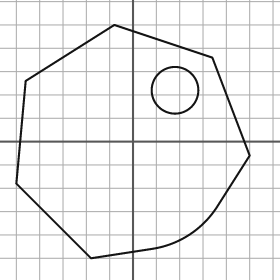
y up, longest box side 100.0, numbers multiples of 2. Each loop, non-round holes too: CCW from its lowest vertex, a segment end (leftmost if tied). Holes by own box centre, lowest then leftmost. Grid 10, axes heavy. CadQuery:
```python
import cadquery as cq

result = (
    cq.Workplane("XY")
    .moveTo(-18.0, -50.0)
    .lineTo(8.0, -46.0)
    .threePointArc((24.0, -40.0), (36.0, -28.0))
    .lineTo(50.0, -6.0)
    .lineTo(34.0, 36.0)
    .lineTo(-8.0, 50.0)
    .lineTo(-46.0, 26.0)
    .lineTo(-50.0, -18.0)
    .close()
    .moveTo(18.0, 22.0)
    .circle(10.0)
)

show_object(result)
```